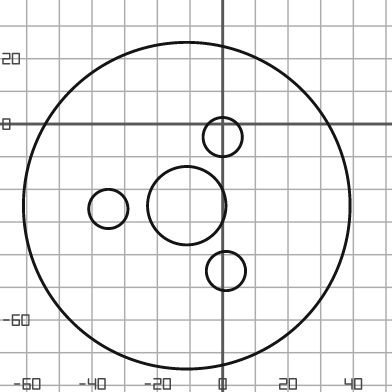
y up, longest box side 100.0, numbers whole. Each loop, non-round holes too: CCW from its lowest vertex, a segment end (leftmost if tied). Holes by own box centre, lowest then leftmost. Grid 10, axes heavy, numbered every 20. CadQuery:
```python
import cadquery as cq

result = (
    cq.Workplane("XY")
    .moveTo(-11.0, -25.0)
    .circle(50.0)
    .moveTo(1.0, -45.0)
    .circle(6.0)
    .moveTo(-35.0, -26.0)
    .circle(6.0)
    .moveTo(-11.0, -25.0)
    .circle(12.0)
    .moveTo(0.0, -4.0)
    .circle(6.0)
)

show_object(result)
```